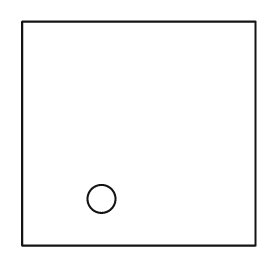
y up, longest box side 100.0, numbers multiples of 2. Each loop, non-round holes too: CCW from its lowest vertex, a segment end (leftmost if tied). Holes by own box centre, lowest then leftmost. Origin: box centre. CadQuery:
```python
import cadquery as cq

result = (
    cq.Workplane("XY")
    .moveTo(-50.0, -48.0)
    .lineTo(50.0, -48.0)
    .lineTo(50.0, 48.0)
    .lineTo(-50.0, 48.0)
    .close()
    .moveTo(-16.0, -28.0)
    .circle(6.0)
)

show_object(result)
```